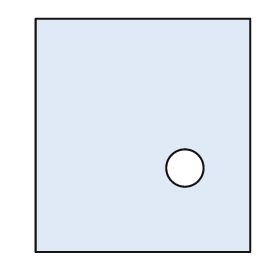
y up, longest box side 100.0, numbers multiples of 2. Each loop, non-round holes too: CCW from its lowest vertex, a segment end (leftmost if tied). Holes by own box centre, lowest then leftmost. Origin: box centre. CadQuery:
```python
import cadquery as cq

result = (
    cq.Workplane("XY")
    .moveTo(-46.0, -50.0)
    .lineTo(46.0, -50.0)
    .lineTo(46.0, 50.0)
    .lineTo(-46.0, 50.0)
    .close()
    .moveTo(18.0, -14.0)
    .circle(8.0)
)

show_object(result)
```